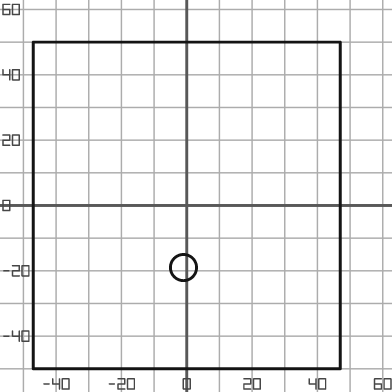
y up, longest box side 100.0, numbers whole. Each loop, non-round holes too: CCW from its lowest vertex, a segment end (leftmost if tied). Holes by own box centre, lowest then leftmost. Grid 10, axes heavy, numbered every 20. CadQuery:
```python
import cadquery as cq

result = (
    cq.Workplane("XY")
    .moveTo(-47.0, -50.0)
    .lineTo(47.0, -50.0)
    .lineTo(47.0, 50.0)
    .lineTo(-47.0, 50.0)
    .close()
    .moveTo(-1.0, -19.0)
    .circle(4.0)
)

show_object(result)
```